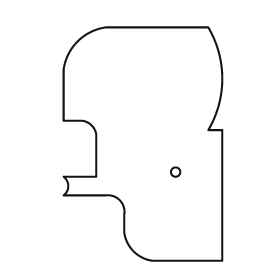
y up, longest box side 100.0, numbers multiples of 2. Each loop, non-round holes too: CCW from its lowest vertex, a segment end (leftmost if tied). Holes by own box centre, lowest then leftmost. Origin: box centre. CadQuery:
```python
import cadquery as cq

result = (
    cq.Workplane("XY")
    .moveTo(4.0, -50.0)
    .lineTo(34.0, -50.0)
    .lineTo(34.0, 6.0)
    .lineTo(28.0, 6.0)
    .threePointArc((34.0, 28.0), (28.0, 50.0))
    .lineTo(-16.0, 50.0)
    .threePointArc((-28.0, 44.0), (-34.0, 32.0))
    .lineTo(-34.0, 10.0)
    .lineTo(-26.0, 10.0)
    .threePointArc((-22.0, 8.0), (-20.0, 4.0))
    .lineTo(-20.0, -14.0)
    .lineTo(-34.0, -14.0)
    .threePointArc((-32.0, -18.0), (-34.0, -22.0))
    .lineTo(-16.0, -22.0)
    .threePointArc((-10.0, -24.0), (-8.0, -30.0))
    .lineTo(-8.0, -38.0)
    .threePointArc((-4.0, -46.0), (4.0, -50.0))
    .close()
    .moveTo(14.0, -12.0)
    .circle(2.0)
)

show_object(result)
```